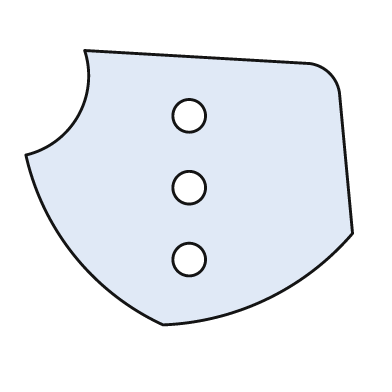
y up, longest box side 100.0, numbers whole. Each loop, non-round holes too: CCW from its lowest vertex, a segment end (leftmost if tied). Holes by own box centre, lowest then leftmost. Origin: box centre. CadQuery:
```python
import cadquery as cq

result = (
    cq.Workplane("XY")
    .moveTo(-8.0, -42.0)
    .threePointArc((24.0, -34.0), (50.0, -14.0))
    .lineTo(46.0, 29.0)
    .threePointArc((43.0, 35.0), (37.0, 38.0))
    .lineTo(-32.0, 42.0)
    .threePointArc((-34.0, 22.0), (-50.0, 10.0))
    .threePointArc((-35.0, -21.0), (-8.0, -42.0))
    .close()
    .moveTo(0.0, -22.0)
    .circle(5.0)
    .moveTo(0.0, 0.0)
    .circle(5.0)
    .moveTo(0.0, 22.0)
    .circle(5.0)
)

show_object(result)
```